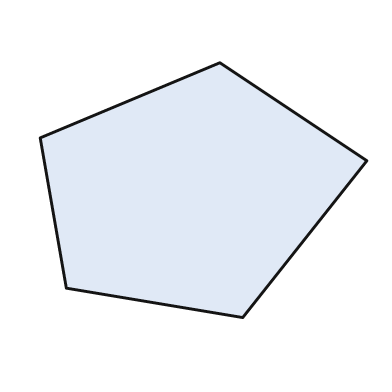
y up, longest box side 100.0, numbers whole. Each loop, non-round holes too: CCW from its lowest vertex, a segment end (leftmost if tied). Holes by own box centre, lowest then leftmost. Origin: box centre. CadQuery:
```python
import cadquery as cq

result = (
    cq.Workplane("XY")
    .moveTo(12.0, -39.0)
    .lineTo(50.0, 9.0)
    .lineTo(5.0, 39.0)
    .lineTo(-50.0, 16.0)
    .lineTo(-42.0, -30.0)
    .close()
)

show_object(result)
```